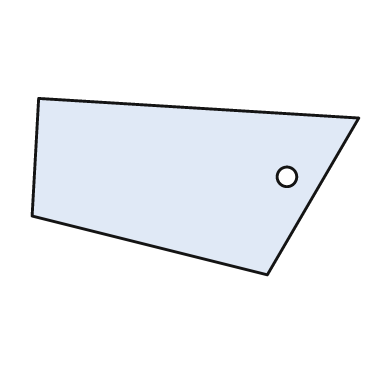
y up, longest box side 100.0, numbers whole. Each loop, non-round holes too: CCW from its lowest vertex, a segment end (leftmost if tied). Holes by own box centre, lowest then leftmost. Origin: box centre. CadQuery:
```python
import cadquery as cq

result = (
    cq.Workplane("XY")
    .moveTo(22.0, -27.0)
    .lineTo(50.0, 21.0)
    .lineTo(-48.0, 27.0)
    .lineTo(-50.0, -9.0)
    .close()
    .moveTo(28.0, 3.0)
    .circle(3.0)
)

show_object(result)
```